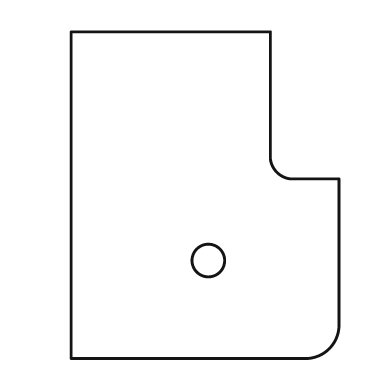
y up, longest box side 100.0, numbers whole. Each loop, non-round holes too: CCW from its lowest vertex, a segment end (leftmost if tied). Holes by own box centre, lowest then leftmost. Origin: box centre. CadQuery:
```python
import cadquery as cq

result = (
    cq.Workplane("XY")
    .moveTo(-41.0, -50.0)
    .lineTo(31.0, -50.0)
    .threePointArc((38.0, -47.0), (41.0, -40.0))
    .lineTo(41.0, 5.0)
    .lineTo(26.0, 5.0)
    .threePointArc((22.0, 7.0), (20.0, 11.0))
    .lineTo(20.0, 50.0)
    .lineTo(-41.0, 50.0)
    .close()
    .moveTo(1.0, -20.0)
    .circle(5.0)
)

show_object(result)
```